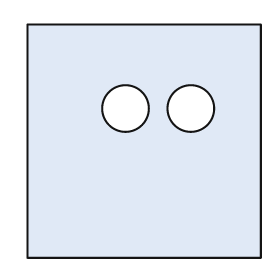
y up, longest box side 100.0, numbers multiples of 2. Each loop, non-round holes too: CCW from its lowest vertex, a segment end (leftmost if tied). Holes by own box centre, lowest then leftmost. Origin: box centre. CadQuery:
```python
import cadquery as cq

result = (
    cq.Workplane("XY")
    .moveTo(-50.0, -50.0)
    .lineTo(50.0, -50.0)
    .lineTo(50.0, 50.0)
    .lineTo(-50.0, 50.0)
    .close()
    .moveTo(-8.0, 14.0)
    .circle(10.0)
    .moveTo(20.0, 14.0)
    .circle(10.0)
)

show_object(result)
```